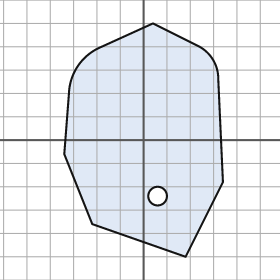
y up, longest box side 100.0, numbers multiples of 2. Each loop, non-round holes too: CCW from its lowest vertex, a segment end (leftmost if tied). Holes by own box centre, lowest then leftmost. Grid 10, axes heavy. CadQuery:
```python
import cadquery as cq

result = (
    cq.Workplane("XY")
    .moveTo(18.0, -50.0)
    .lineTo(34.0, -18.0)
    .lineTo(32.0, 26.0)
    .threePointArc((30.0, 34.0), (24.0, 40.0))
    .lineTo(4.0, 50.0)
    .lineTo(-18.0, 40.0)
    .threePointArc((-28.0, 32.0), (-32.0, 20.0))
    .lineTo(-34.0, -6.0)
    .lineTo(-22.0, -36.0)
    .close()
    .moveTo(6.0, -24.0)
    .circle(4.0)
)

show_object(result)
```